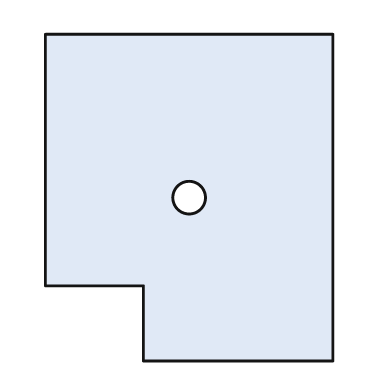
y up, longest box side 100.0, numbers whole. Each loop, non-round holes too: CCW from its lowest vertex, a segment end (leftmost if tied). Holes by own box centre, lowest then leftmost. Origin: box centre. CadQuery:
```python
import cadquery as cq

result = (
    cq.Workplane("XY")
    .moveTo(-14.0, -50.0)
    .lineTo(44.0, -50.0)
    .lineTo(44.0, 50.0)
    .lineTo(-44.0, 50.0)
    .lineTo(-44.0, -27.0)
    .lineTo(-14.0, -27.0)
    .close()
    .moveTo(0.0, 0.0)
    .circle(5.0)
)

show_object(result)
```